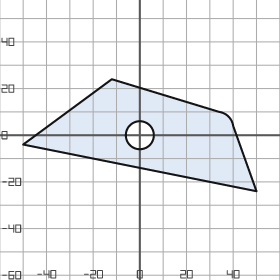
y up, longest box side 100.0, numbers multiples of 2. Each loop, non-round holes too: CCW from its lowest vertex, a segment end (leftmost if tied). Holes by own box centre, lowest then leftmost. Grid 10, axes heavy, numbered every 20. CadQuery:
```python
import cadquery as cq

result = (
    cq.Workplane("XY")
    .moveTo(50.0, -24.0)
    .lineTo(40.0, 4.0)
    .threePointArc((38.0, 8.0), (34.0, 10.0))
    .lineTo(-12.0, 24.0)
    .lineTo(-50.0, -4.0)
    .close()
    .moveTo(0.0, 0.0)
    .circle(6.0)
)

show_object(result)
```